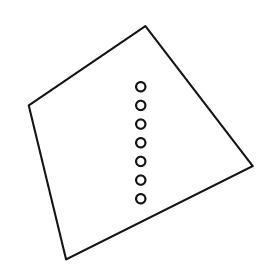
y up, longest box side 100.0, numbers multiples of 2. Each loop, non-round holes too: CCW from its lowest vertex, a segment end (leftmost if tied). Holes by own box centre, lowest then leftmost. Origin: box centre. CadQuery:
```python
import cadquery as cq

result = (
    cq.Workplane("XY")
    .moveTo(-32.0, -50.0)
    .lineTo(48.0, -10.0)
    .lineTo(2.0, 50.0)
    .lineTo(-48.0, 16.0)
    .close()
    .moveTo(0.0, -24.0)
    .circle(2.0)
    .moveTo(0.0, -16.0)
    .circle(2.0)
    .moveTo(0.0, -8.0)
    .circle(2.0)
    .moveTo(0.0, 0.0)
    .circle(2.0)
    .moveTo(0.0, 8.0)
    .circle(2.0)
    .moveTo(0.0, 16.0)
    .circle(2.0)
    .moveTo(0.0, 24.0)
    .circle(2.0)
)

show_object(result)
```